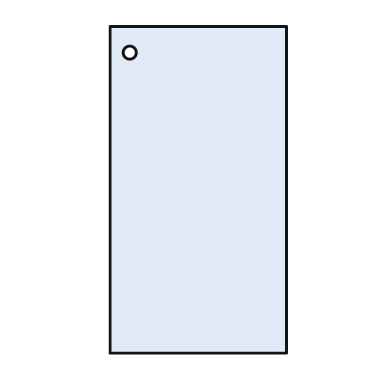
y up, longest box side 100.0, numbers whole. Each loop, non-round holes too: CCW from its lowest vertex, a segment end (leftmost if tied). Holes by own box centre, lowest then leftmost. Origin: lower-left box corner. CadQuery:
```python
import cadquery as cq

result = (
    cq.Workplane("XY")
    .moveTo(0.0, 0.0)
    .lineTo(54.0, 0.0)
    .lineTo(54.0, 100.0)
    .lineTo(0.0, 100.0)
    .close()
    .moveTo(6.0, 92.0)
    .circle(2.0)
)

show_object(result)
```